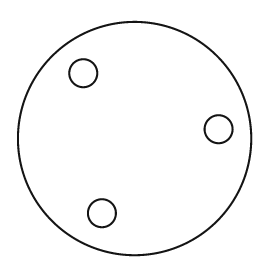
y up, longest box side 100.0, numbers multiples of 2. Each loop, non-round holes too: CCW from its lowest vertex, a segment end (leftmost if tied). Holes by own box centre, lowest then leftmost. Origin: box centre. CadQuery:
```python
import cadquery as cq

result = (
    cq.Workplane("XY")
    .moveTo(0.0, 0.0)
    .circle(50.0)
    .moveTo(-14.0, -32.0)
    .circle(6.0)
    .moveTo(36.0, 4.0)
    .circle(6.0)
    .moveTo(-22.0, 28.0)
    .circle(6.0)
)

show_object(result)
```